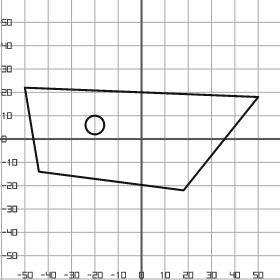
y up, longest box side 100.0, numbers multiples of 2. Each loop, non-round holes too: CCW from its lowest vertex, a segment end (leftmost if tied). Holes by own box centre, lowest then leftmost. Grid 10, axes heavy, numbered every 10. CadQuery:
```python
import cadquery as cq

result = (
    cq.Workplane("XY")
    .moveTo(18.0, -22.0)
    .lineTo(50.0, 18.0)
    .lineTo(-50.0, 22.0)
    .lineTo(-44.0, -14.0)
    .close()
    .moveTo(-20.0, 6.0)
    .circle(4.0)
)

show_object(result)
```